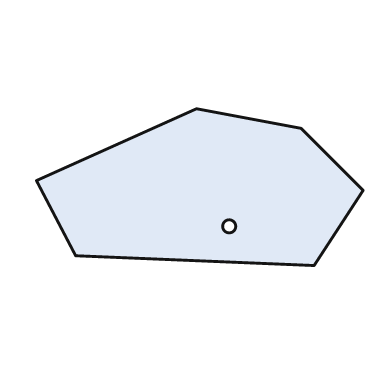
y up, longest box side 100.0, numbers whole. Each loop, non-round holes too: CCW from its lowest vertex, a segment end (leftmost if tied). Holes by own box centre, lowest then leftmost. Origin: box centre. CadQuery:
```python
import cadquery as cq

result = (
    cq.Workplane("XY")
    .moveTo(35.0, -24.0)
    .lineTo(50.0, -1.0)
    .lineTo(31.0, 18.0)
    .lineTo(-1.0, 24.0)
    .lineTo(-50.0, 2.0)
    .lineTo(-38.0, -21.0)
    .close()
    .moveTo(9.0, -12.0)
    .circle(2.0)
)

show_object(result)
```